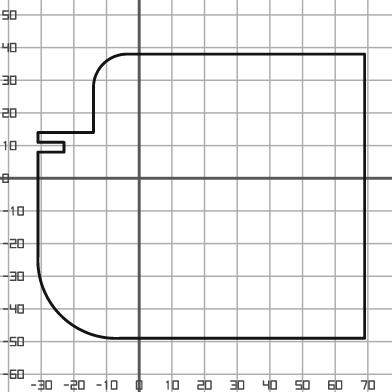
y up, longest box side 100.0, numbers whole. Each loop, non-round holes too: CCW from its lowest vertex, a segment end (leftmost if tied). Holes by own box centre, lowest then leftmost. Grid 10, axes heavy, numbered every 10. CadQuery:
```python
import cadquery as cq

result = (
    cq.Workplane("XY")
    .moveTo(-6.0, -49.0)
    .lineTo(69.0, -49.0)
    .lineTo(69.0, 38.0)
    .lineTo(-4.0, 38.0)
    .threePointArc((-11.0, 35.0), (-14.0, 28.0))
    .lineTo(-14.0, 14.0)
    .lineTo(-31.0, 14.0)
    .lineTo(-31.0, 11.0)
    .lineTo(-23.0, 11.0)
    .lineTo(-23.0, 8.0)
    .lineTo(-31.0, 8.0)
    .lineTo(-31.0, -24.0)
    .threePointArc((-24.0, -42.0), (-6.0, -49.0))
    .close()
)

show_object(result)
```